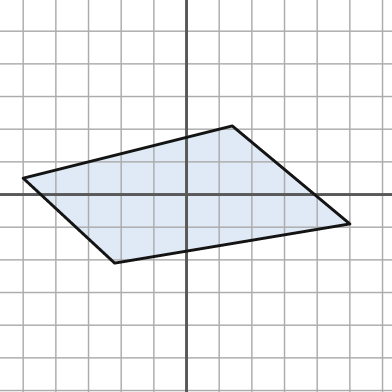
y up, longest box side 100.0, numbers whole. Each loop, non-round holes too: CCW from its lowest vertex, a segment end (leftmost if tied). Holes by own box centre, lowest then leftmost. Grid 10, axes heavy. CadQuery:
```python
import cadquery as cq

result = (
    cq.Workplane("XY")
    .moveTo(-22.0, -21.0)
    .lineTo(50.0, -9.0)
    .lineTo(14.0, 21.0)
    .lineTo(-50.0, 5.0)
    .close()
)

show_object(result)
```